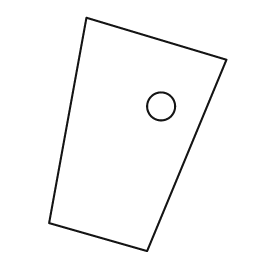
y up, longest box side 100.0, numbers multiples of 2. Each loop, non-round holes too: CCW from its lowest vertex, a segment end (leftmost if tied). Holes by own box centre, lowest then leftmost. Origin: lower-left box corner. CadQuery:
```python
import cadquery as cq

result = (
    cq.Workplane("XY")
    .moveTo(42.0, 0.0)
    .lineTo(76.0, 82.0)
    .lineTo(16.0, 100.0)
    .lineTo(0.0, 12.0)
    .close()
    .moveTo(48.0, 62.0)
    .circle(6.0)
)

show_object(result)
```